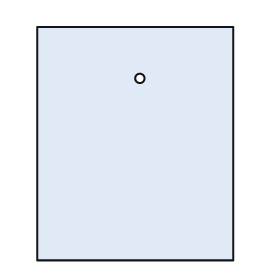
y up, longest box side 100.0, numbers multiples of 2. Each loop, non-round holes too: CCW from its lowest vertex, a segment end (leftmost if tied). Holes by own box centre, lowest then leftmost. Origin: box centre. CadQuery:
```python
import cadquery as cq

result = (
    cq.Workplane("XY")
    .moveTo(-42.0, -50.0)
    .lineTo(42.0, -50.0)
    .lineTo(42.0, 50.0)
    .lineTo(-42.0, 50.0)
    .close()
    .moveTo(2.0, 28.0)
    .circle(2.0)
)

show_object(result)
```